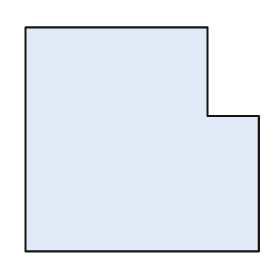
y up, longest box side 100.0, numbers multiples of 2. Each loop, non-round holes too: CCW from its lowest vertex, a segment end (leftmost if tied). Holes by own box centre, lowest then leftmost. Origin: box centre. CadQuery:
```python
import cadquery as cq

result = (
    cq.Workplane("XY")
    .moveTo(-50.0, -48.0)
    .lineTo(50.0, -48.0)
    .lineTo(50.0, 10.0)
    .lineTo(28.0, 10.0)
    .lineTo(28.0, 48.0)
    .lineTo(-50.0, 48.0)
    .close()
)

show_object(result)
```